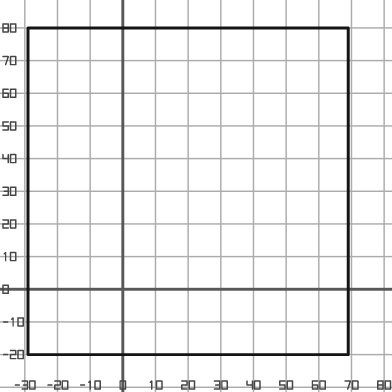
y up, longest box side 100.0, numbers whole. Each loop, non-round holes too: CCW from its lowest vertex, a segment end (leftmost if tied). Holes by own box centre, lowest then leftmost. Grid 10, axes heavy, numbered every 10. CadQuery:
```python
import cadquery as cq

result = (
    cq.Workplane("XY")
    .moveTo(-29.0, -20.0)
    .lineTo(69.0, -20.0)
    .lineTo(69.0, 80.0)
    .lineTo(-29.0, 80.0)
    .close()
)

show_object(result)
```